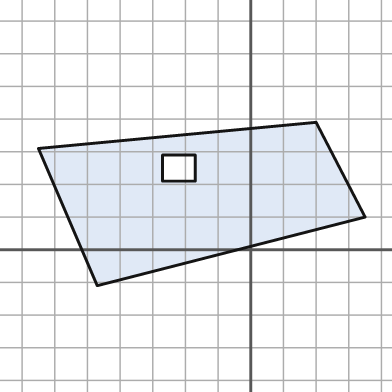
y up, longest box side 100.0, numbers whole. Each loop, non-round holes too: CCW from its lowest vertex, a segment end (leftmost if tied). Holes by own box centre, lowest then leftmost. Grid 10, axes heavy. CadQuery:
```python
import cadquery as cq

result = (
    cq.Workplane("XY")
    .moveTo(-47.0, -11.0)
    .lineTo(35.0, 10.0)
    .lineTo(20.0, 39.0)
    .lineTo(-65.0, 31.0)
    .close()
    .moveTo(-27.0, 21.0)
    .lineTo(-17.0, 21.0)
    .lineTo(-17.0, 29.0)
    .lineTo(-27.0, 29.0)
    .close()
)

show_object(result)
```